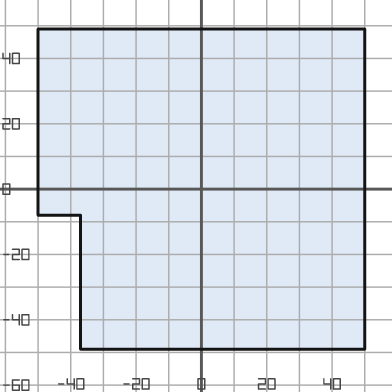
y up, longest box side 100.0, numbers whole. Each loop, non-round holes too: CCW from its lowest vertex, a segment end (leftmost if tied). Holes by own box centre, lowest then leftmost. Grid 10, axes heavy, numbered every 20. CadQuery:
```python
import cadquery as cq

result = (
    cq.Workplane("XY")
    .moveTo(-37.0, -49.0)
    .lineTo(50.0, -49.0)
    .lineTo(50.0, 49.0)
    .lineTo(-50.0, 49.0)
    .lineTo(-50.0, -8.0)
    .lineTo(-37.0, -8.0)
    .close()
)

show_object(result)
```